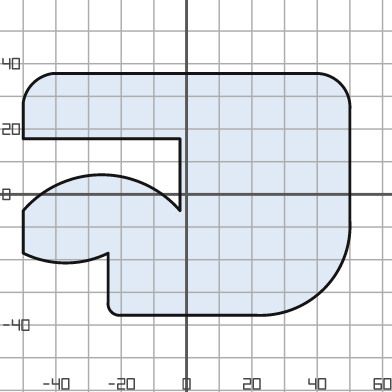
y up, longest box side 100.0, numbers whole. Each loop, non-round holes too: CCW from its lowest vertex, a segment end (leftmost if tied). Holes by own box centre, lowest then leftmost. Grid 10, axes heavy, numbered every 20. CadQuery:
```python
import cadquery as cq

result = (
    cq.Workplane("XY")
    .moveTo(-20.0, -37.0)
    .lineTo(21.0, -37.0)
    .threePointArc((42.0, -29.0), (50.0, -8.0))
    .lineTo(50.0, 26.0)
    .threePointArc((47.0, 34.0), (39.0, 37.0))
    .lineTo(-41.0, 37.0)
    .threePointArc((-47.0, 34.0), (-50.0, 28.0))
    .lineTo(-50.0, 17.0)
    .lineTo(-2.0, 17.0)
    .lineTo(-2.0, -5.0)
    .threePointArc((-26.0, 6.0), (-50.0, -5.0))
    .lineTo(-50.0, -18.0)
    .threePointArc((-37.0, -21.0), (-24.0, -18.0))
    .lineTo(-24.0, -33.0)
    .threePointArc((-23.0, -36.0), (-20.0, -37.0))
    .close()
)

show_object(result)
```